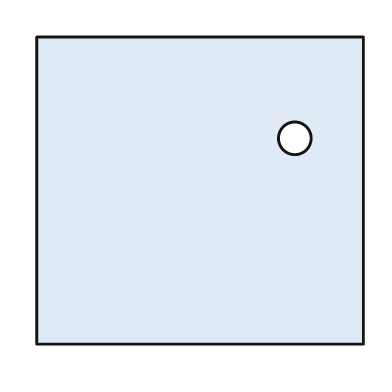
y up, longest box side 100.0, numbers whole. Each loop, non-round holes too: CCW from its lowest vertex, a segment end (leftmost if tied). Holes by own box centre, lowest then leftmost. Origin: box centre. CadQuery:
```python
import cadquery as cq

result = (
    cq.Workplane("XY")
    .moveTo(-50.0, -47.0)
    .lineTo(50.0, -47.0)
    .lineTo(50.0, 47.0)
    .lineTo(-50.0, 47.0)
    .close()
    .moveTo(29.0, 16.0)
    .circle(5.0)
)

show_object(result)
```